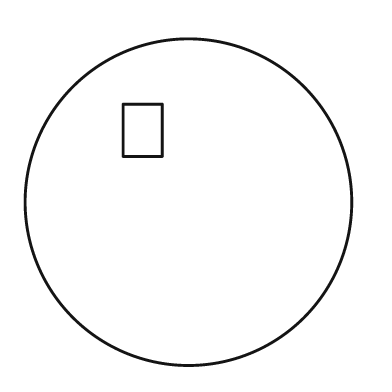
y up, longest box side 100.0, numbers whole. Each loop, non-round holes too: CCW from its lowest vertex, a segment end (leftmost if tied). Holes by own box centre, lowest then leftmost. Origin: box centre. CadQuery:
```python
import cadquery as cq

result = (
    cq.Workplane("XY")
    .moveTo(0.0, 0.0)
    .circle(50.0)
    .moveTo(-20.0, 14.0)
    .lineTo(-8.0, 14.0)
    .lineTo(-8.0, 30.0)
    .lineTo(-20.0, 30.0)
    .close()
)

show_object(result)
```